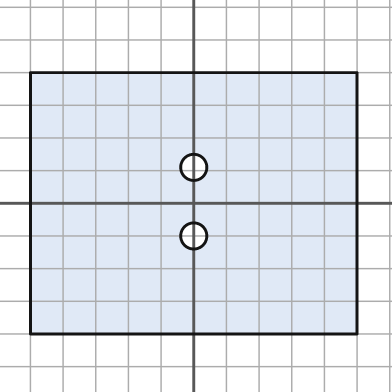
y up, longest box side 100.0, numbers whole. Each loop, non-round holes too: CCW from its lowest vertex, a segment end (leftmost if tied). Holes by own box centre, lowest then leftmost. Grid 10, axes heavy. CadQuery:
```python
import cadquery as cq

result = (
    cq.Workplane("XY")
    .moveTo(-50.0, -40.0)
    .lineTo(50.0, -40.0)
    .lineTo(50.0, 40.0)
    .lineTo(-50.0, 40.0)
    .close()
    .moveTo(0.0, -10.0)
    .circle(4.0)
    .moveTo(0.0, 11.0)
    .circle(4.0)
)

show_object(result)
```